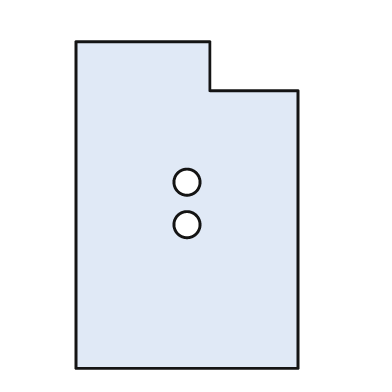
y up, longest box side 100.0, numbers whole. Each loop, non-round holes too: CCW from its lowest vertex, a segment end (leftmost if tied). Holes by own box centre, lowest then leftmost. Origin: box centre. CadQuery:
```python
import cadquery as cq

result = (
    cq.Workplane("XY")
    .moveTo(-34.0, -50.0)
    .lineTo(34.0, -50.0)
    .lineTo(34.0, 35.0)
    .lineTo(7.0, 35.0)
    .lineTo(7.0, 50.0)
    .lineTo(-34.0, 50.0)
    .close()
    .moveTo(0.0, -6.0)
    .circle(4.0)
    .moveTo(0.0, 7.0)
    .circle(4.0)
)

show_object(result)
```